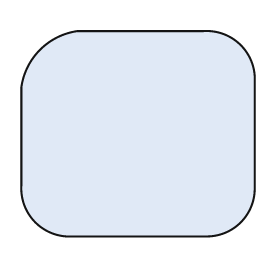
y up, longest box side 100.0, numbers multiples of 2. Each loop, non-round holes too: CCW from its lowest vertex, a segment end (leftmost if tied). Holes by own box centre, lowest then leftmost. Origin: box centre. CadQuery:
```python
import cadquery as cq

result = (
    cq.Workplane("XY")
    .moveTo(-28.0, -44.0)
    .lineTo(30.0, -44.0)
    .threePointArc((44.0, -38.0), (50.0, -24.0))
    .lineTo(50.0, 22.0)
    .threePointArc((44.0, 38.0), (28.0, 44.0))
    .lineTo(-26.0, 44.0)
    .threePointArc((-42.0, 36.0), (-50.0, 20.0))
    .lineTo(-50.0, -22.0)
    .threePointArc((-44.0, -38.0), (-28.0, -44.0))
    .close()
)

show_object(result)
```